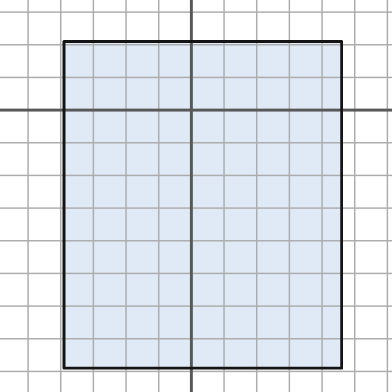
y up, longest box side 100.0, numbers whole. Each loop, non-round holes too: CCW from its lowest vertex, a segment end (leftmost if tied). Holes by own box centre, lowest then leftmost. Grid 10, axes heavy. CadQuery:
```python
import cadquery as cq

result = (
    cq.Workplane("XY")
    .moveTo(-39.0, -79.0)
    .lineTo(46.0, -79.0)
    .lineTo(46.0, 21.0)
    .lineTo(-39.0, 21.0)
    .close()
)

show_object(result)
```